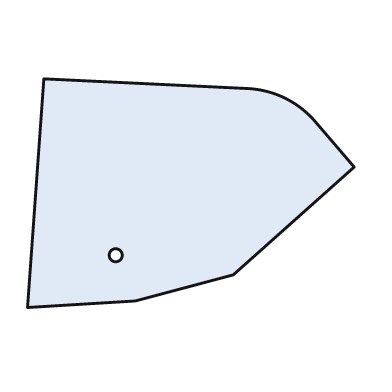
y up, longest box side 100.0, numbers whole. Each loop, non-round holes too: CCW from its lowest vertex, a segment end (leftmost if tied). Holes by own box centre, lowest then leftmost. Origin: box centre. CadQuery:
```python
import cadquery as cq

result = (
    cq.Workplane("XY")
    .moveTo(-50.0, -35.0)
    .lineTo(-17.0, -33.0)
    .lineTo(13.0, -25.0)
    .lineTo(50.0, 8.0)
    .lineTo(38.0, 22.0)
    .threePointArc((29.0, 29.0), (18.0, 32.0))
    .lineTo(-45.0, 35.0)
    .close()
    .moveTo(-23.0, -19.0)
    .circle(2.0)
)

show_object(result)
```